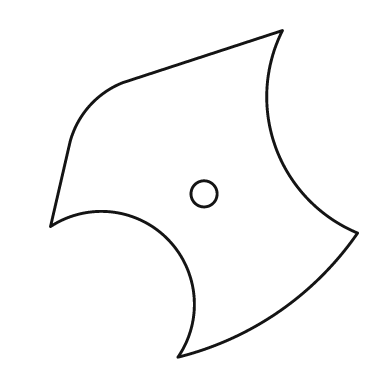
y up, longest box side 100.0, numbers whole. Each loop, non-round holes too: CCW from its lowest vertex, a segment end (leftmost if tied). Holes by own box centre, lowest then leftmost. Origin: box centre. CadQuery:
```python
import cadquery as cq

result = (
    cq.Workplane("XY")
    .moveTo(-8.0, -50.0)
    .threePointArc((23.0, -36.0), (47.0, -12.0))
    .threePointArc((22.0, 14.0), (24.0, 50.0))
    .lineTo(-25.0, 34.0)
    .threePointArc((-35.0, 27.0), (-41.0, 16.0))
    .lineTo(-47.0, -10.0)
    .threePointArc((-11.0, -14.0), (-8.0, -50.0))
    .close()
    .moveTo(0.0, 0.0)
    .circle(4.0)
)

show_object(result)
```